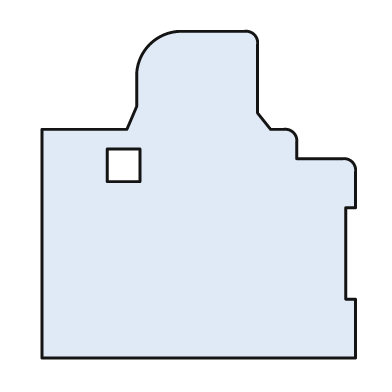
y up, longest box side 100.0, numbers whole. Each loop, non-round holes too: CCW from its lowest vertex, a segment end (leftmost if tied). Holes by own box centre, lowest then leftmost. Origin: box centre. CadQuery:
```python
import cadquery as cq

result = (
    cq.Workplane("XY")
    .moveTo(-48.0, -50.0)
    .lineTo(48.0, -50.0)
    .lineTo(48.0, -32.0)
    .lineTo(45.0, -32.0)
    .lineTo(45.0, -4.0)
    .lineTo(48.0, -4.0)
    .lineTo(48.0, 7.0)
    .threePointArc((47.0, 10.0), (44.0, 11.0))
    .lineTo(30.0, 11.0)
    .lineTo(30.0, 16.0)
    .threePointArc((29.0, 19.0), (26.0, 20.0))
    .lineTo(22.0, 20.0)
    .lineTo(18.0, 25.0)
    .lineTo(18.0, 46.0)
    .threePointArc((17.0, 49.0), (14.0, 50.0))
    .lineTo(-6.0, 50.0)
    .threePointArc((-15.0, 46.0), (-19.0, 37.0))
    .lineTo(-19.0, 27.0)
    .lineTo(-22.0, 20.0)
    .lineTo(-48.0, 20.0)
    .close()
    .moveTo(-28.0, 4.0)
    .lineTo(-18.0, 4.0)
    .lineTo(-18.0, 14.0)
    .lineTo(-28.0, 14.0)
    .close()
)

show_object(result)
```